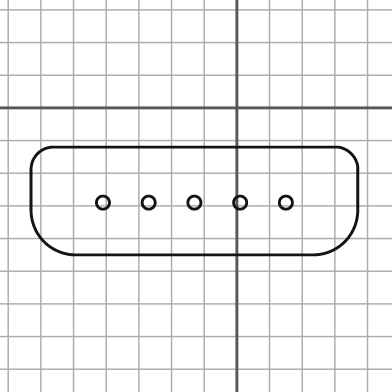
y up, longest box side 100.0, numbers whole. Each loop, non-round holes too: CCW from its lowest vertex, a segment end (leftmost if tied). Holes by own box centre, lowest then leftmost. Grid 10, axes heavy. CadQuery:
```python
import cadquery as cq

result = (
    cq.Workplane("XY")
    .moveTo(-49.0, -45.0)
    .lineTo(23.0, -45.0)
    .threePointArc((33.0, -41.0), (37.0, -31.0))
    .lineTo(37.0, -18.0)
    .threePointArc((35.0, -14.0), (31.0, -12.0))
    .lineTo(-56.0, -12.0)
    .threePointArc((-61.0, -14.0), (-63.0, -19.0))
    .lineTo(-63.0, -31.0)
    .threePointArc((-59.0, -41.0), (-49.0, -45.0))
    .close()
    .moveTo(-41.0, -29.0)
    .circle(2.0)
    .moveTo(-27.0, -29.0)
    .circle(2.0)
    .moveTo(-13.0, -29.0)
    .circle(2.0)
    .moveTo(1.0, -29.0)
    .circle(2.0)
    .moveTo(15.0, -29.0)
    .circle(2.0)
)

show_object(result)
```